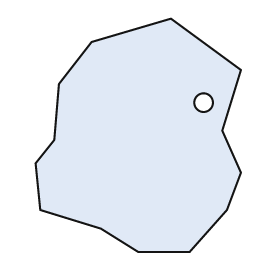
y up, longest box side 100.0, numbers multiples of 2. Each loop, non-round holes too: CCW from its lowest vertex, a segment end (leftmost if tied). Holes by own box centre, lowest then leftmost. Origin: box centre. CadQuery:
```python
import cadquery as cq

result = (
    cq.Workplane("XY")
    .moveTo(0.0, -50.0)
    .lineTo(22.0, -50.0)
    .lineTo(38.0, -32.0)
    .lineTo(44.0, -16.0)
    .lineTo(36.0, 2.0)
    .lineTo(44.0, 28.0)
    .lineTo(14.0, 50.0)
    .lineTo(-20.0, 40.0)
    .lineTo(-34.0, 22.0)
    .lineTo(-36.0, -2.0)
    .lineTo(-44.0, -12.0)
    .lineTo(-42.0, -32.0)
    .lineTo(-16.0, -40.0)
    .close()
    .moveTo(28.0, 14.0)
    .circle(4.0)
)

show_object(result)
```